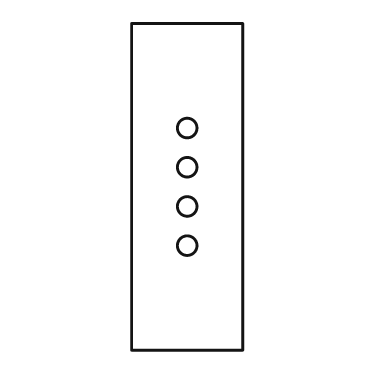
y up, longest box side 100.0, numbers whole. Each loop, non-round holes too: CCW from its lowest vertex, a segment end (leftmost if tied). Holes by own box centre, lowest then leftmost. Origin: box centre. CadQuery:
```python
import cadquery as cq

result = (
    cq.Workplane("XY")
    .moveTo(-17.0, -50.0)
    .lineTo(17.0, -50.0)
    .lineTo(17.0, 50.0)
    .lineTo(-17.0, 50.0)
    .close()
    .moveTo(0.0, -18.0)
    .circle(3.0)
    .moveTo(0.0, -6.0)
    .circle(3.0)
    .moveTo(0.0, 6.0)
    .circle(3.0)
    .moveTo(0.0, 18.0)
    .circle(3.0)
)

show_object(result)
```